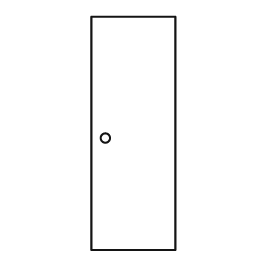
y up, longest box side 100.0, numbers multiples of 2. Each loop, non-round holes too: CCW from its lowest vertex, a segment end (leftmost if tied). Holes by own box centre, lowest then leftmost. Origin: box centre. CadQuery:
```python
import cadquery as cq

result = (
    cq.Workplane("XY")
    .moveTo(-18.0, -50.0)
    .lineTo(18.0, -50.0)
    .lineTo(18.0, 50.0)
    .lineTo(-18.0, 50.0)
    .close()
    .moveTo(-12.0, -2.0)
    .circle(2.0)
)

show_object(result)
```